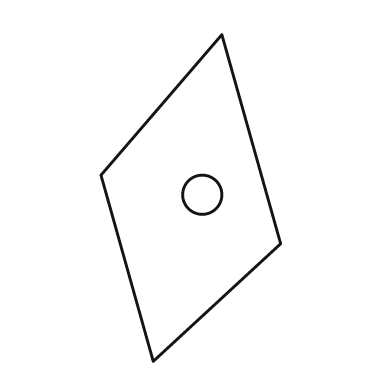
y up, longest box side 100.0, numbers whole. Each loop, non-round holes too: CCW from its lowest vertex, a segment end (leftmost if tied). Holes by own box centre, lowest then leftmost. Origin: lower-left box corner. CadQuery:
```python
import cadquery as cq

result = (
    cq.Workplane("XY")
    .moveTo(16.0, 0.0)
    .lineTo(55.0, 36.0)
    .lineTo(37.0, 100.0)
    .lineTo(0.0, 57.0)
    .close()
    .moveTo(31.0, 51.0)
    .circle(6.0)
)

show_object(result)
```